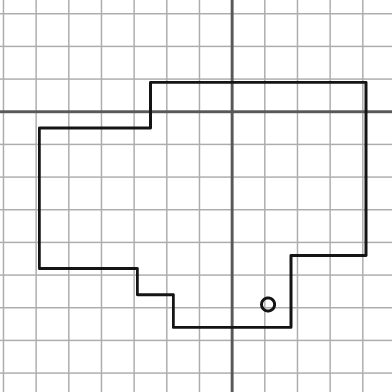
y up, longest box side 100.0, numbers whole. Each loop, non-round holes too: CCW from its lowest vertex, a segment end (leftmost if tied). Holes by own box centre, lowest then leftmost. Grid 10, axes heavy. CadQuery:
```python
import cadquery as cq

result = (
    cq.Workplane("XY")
    .moveTo(-18.0, -66.0)
    .lineTo(18.0, -66.0)
    .lineTo(18.0, -44.0)
    .lineTo(41.0, -44.0)
    .lineTo(41.0, 9.0)
    .lineTo(-25.0, 9.0)
    .lineTo(-25.0, -5.0)
    .lineTo(-59.0, -5.0)
    .lineTo(-59.0, -48.0)
    .lineTo(-29.0, -48.0)
    .lineTo(-29.0, -56.0)
    .lineTo(-18.0, -56.0)
    .close()
    .moveTo(11.0, -59.0)
    .circle(2.0)
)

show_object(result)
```